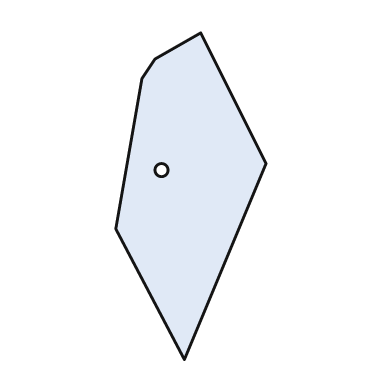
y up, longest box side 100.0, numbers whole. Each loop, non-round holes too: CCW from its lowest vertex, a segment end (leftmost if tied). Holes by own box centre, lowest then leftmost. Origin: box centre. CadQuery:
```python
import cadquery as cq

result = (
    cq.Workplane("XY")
    .moveTo(-2.0, -50.0)
    .lineTo(23.0, 10.0)
    .lineTo(3.0, 50.0)
    .lineTo(-11.0, 42.0)
    .lineTo(-15.0, 36.0)
    .lineTo(-23.0, -10.0)
    .close()
    .moveTo(-9.0, 8.0)
    .circle(2.0)
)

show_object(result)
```